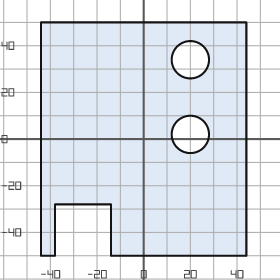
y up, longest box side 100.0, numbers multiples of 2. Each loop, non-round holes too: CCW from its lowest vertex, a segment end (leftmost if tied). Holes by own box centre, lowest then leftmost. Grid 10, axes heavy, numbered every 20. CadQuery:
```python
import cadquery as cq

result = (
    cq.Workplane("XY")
    .moveTo(-44.0, -50.0)
    .lineTo(-38.0, -50.0)
    .lineTo(-38.0, -28.0)
    .lineTo(-14.0, -28.0)
    .lineTo(-14.0, -50.0)
    .lineTo(44.0, -50.0)
    .lineTo(44.0, 50.0)
    .lineTo(-44.0, 50.0)
    .close()
    .moveTo(20.0, 2.0)
    .circle(8.0)
    .moveTo(20.0, 34.0)
    .circle(8.0)
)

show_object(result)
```